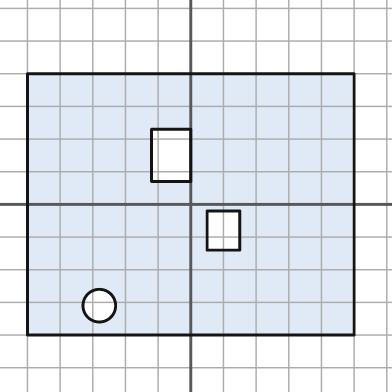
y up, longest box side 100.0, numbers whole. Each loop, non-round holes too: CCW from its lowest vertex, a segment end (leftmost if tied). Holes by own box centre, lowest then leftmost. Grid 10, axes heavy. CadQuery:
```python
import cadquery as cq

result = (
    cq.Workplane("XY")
    .moveTo(-50.0, -40.0)
    .lineTo(50.0, -40.0)
    .lineTo(50.0, 40.0)
    .lineTo(-50.0, 40.0)
    .close()
    .moveTo(-28.0, -31.0)
    .circle(5.0)
    .moveTo(5.0, -14.0)
    .lineTo(15.0, -14.0)
    .lineTo(15.0, -2.0)
    .lineTo(5.0, -2.0)
    .close()
    .moveTo(-12.0, 7.0)
    .lineTo(0.0, 7.0)
    .lineTo(0.0, 23.0)
    .lineTo(-12.0, 23.0)
    .close()
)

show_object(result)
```